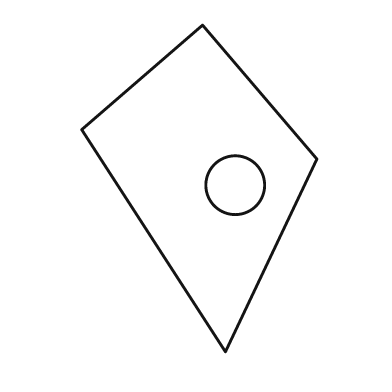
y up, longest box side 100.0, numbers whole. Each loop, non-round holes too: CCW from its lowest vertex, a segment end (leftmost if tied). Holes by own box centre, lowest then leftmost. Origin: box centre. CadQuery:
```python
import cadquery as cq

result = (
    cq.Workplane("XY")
    .moveTo(8.0, -50.0)
    .lineTo(36.0, 9.0)
    .lineTo(1.0, 50.0)
    .lineTo(-36.0, 18.0)
    .close()
    .moveTo(11.0, 1.0)
    .circle(9.0)
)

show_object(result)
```